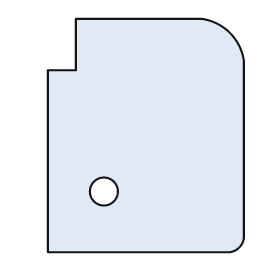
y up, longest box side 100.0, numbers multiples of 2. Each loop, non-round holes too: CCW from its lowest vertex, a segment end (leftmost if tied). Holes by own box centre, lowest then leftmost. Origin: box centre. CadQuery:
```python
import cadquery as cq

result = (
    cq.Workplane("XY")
    .moveTo(-42.0, -50.0)
    .lineTo(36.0, -50.0)
    .threePointArc((40.0, -48.0), (42.0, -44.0))
    .lineTo(42.0, 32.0)
    .threePointArc((36.0, 44.0), (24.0, 50.0))
    .lineTo(-30.0, 50.0)
    .lineTo(-30.0, 28.0)
    .lineTo(-42.0, 28.0)
    .close()
    .moveTo(-18.0, -24.0)
    .circle(6.0)
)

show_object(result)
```